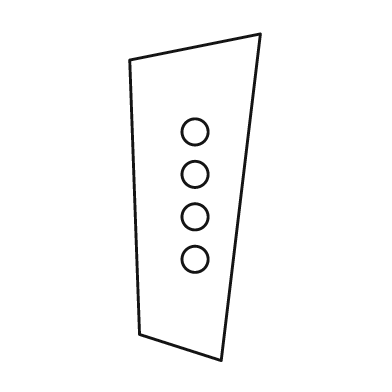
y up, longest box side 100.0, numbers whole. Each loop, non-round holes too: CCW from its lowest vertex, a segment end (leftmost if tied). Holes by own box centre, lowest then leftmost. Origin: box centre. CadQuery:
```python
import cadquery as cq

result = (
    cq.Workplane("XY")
    .moveTo(8.0, -50.0)
    .lineTo(20.0, 50.0)
    .lineTo(-20.0, 42.0)
    .lineTo(-17.0, -42.0)
    .close()
    .moveTo(0.0, -19.0)
    .circle(4.0)
    .moveTo(0.0, -6.0)
    .circle(4.0)
    .moveTo(0.0, 7.0)
    .circle(4.0)
    .moveTo(0.0, 20.0)
    .circle(4.0)
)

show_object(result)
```